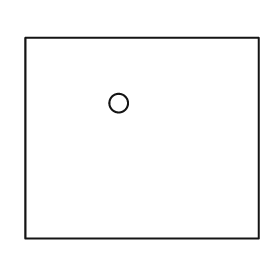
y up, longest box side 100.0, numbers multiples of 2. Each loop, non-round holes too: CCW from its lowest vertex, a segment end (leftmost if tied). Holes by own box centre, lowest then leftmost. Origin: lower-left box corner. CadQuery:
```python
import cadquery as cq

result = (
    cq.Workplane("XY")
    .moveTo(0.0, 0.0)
    .lineTo(100.0, 0.0)
    .lineTo(100.0, 86.0)
    .lineTo(0.0, 86.0)
    .close()
    .moveTo(40.0, 58.0)
    .circle(4.0)
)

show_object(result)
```